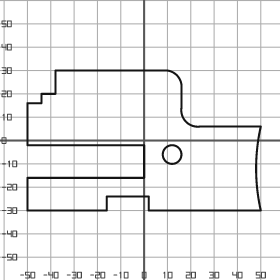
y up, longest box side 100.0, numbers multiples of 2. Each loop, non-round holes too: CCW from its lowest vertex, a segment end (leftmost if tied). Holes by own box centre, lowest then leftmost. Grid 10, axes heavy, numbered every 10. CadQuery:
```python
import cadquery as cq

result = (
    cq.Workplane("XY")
    .moveTo(-50.0, -30.0)
    .lineTo(-16.0, -30.0)
    .lineTo(-16.0, -24.0)
    .lineTo(2.0, -24.0)
    .lineTo(2.0, -30.0)
    .lineTo(50.0, -30.0)
    .threePointArc((48.0, -12.0), (50.0, 6.0))
    .lineTo(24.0, 6.0)
    .threePointArc((18.0, 8.0), (16.0, 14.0))
    .lineTo(16.0, 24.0)
    .threePointArc((14.0, 28.0), (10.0, 30.0))
    .lineTo(-38.0, 30.0)
    .lineTo(-38.0, 20.0)
    .lineTo(-44.0, 20.0)
    .lineTo(-44.0, 16.0)
    .lineTo(-50.0, 16.0)
    .lineTo(-50.0, -2.0)
    .lineTo(0.0, -2.0)
    .lineTo(0.0, -16.0)
    .lineTo(-50.0, -16.0)
    .close()
    .moveTo(12.0, -6.0)
    .circle(4.0)
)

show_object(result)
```